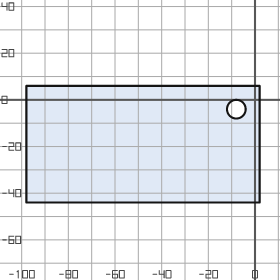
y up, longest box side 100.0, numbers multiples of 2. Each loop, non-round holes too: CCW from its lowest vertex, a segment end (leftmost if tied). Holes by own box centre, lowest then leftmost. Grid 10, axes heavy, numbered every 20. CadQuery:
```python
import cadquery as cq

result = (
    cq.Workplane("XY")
    .moveTo(-98.0, -44.0)
    .lineTo(2.0, -44.0)
    .lineTo(2.0, 6.0)
    .lineTo(-98.0, 6.0)
    .close()
    .moveTo(-8.0, -4.0)
    .circle(4.0)
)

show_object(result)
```